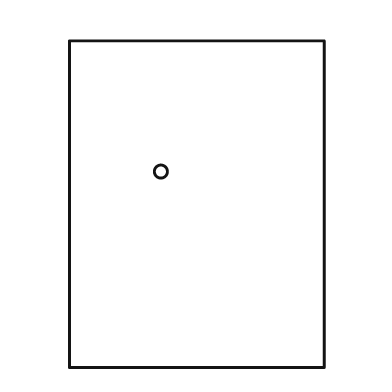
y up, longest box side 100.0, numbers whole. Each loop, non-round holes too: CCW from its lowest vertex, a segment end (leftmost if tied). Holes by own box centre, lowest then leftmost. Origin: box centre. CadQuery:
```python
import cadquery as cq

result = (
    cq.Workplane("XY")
    .moveTo(-39.0, -50.0)
    .lineTo(39.0, -50.0)
    .lineTo(39.0, 50.0)
    .lineTo(-39.0, 50.0)
    .close()
    .moveTo(-11.0, 10.0)
    .circle(2.0)
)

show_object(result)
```